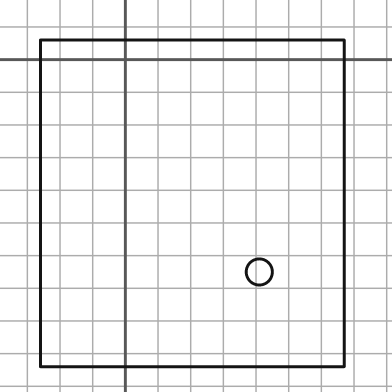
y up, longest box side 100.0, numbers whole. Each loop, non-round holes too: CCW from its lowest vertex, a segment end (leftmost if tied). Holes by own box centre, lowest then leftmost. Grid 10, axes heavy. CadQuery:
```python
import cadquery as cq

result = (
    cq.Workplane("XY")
    .moveTo(-26.0, -94.0)
    .lineTo(67.0, -94.0)
    .lineTo(67.0, 6.0)
    .lineTo(-26.0, 6.0)
    .close()
    .moveTo(41.0, -65.0)
    .circle(4.0)
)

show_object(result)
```